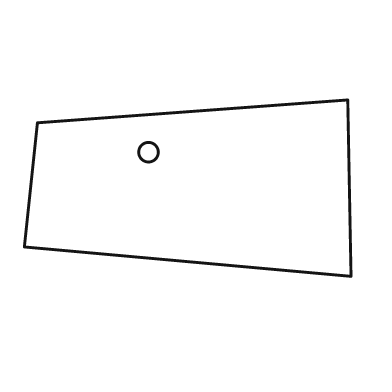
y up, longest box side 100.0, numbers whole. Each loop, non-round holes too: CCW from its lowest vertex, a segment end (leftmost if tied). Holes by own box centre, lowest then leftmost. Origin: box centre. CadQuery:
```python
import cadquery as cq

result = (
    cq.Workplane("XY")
    .moveTo(50.0, -27.0)
    .lineTo(49.0, 27.0)
    .lineTo(-46.0, 20.0)
    .lineTo(-50.0, -18.0)
    .close()
    .moveTo(-12.0, 11.0)
    .circle(3.0)
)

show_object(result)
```